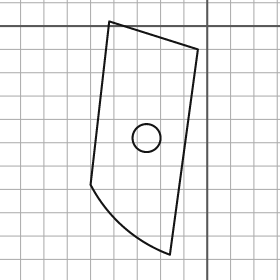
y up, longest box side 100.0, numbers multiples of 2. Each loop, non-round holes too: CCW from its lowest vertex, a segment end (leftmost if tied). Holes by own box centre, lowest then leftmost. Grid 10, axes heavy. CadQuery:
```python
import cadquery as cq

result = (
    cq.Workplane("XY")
    .moveTo(-16.0, -98.0)
    .lineTo(-4.0, -10.0)
    .lineTo(-42.0, 2.0)
    .lineTo(-50.0, -68.0)
    .threePointArc((-36.0, -86.0), (-16.0, -98.0))
    .close()
    .moveTo(-26.0, -48.0)
    .circle(6.0)
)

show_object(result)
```